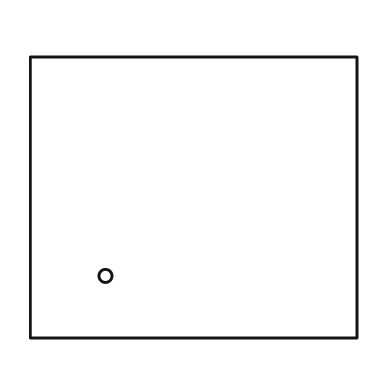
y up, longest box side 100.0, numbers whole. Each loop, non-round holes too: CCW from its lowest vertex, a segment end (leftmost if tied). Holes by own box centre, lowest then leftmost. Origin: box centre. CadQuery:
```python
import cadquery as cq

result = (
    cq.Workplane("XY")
    .moveTo(-50.0, -43.0)
    .lineTo(50.0, -43.0)
    .lineTo(50.0, 43.0)
    .lineTo(-50.0, 43.0)
    .close()
    .moveTo(-27.0, -24.0)
    .circle(2.0)
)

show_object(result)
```